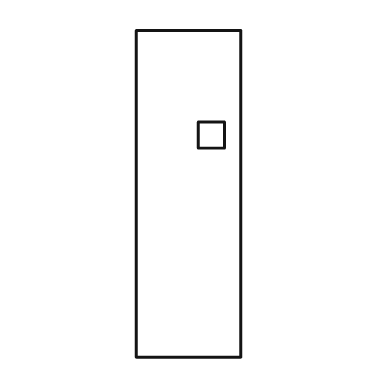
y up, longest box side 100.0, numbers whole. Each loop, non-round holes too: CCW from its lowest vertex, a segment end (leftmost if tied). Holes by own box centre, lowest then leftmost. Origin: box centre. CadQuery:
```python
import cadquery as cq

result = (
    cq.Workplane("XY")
    .moveTo(-16.0, -50.0)
    .lineTo(16.0, -50.0)
    .lineTo(16.0, 50.0)
    .lineTo(-16.0, 50.0)
    .close()
    .moveTo(3.0, 14.0)
    .lineTo(11.0, 14.0)
    .lineTo(11.0, 22.0)
    .lineTo(3.0, 22.0)
    .close()
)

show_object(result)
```